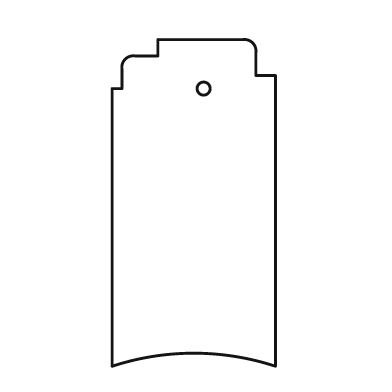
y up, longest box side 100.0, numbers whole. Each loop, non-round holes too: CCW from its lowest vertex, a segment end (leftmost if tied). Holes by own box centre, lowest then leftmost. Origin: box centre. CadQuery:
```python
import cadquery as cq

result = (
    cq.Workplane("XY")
    .moveTo(-25.0, -50.0)
    .threePointArc((0.0, -46.0), (25.0, -50.0))
    .lineTo(25.0, 39.0)
    .lineTo(19.0, 39.0)
    .lineTo(19.0, 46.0)
    .threePointArc((18.0, 49.0), (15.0, 50.0))
    .lineTo(-11.0, 50.0)
    .lineTo(-11.0, 45.0)
    .lineTo(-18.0, 45.0)
    .threePointArc((-21.0, 44.0), (-22.0, 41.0))
    .lineTo(-22.0, 35.0)
    .lineTo(-25.0, 35.0)
    .close()
    .moveTo(3.0, 35.0)
    .circle(2.0)
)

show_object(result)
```